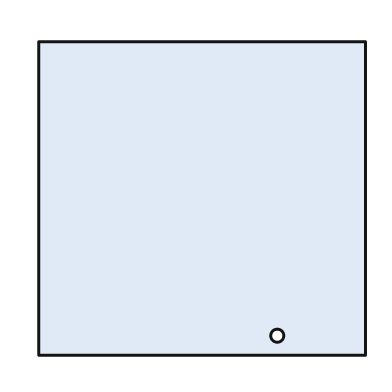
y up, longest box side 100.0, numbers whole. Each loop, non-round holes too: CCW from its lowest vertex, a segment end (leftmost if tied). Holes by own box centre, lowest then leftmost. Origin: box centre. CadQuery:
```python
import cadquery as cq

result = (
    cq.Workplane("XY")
    .moveTo(-50.0, -48.0)
    .lineTo(50.0, -48.0)
    .lineTo(50.0, 48.0)
    .lineTo(-50.0, 48.0)
    .close()
    .moveTo(23.0, -42.0)
    .circle(2.0)
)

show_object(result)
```